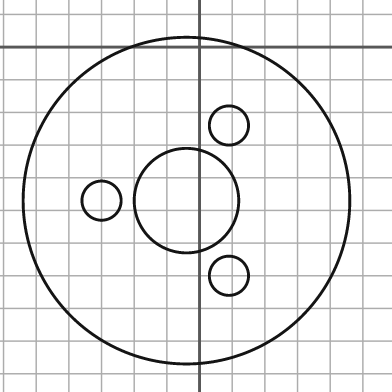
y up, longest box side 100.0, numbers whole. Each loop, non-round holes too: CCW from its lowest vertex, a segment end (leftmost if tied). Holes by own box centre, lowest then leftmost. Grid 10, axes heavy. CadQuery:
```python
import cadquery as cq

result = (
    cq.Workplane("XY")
    .moveTo(-4.0, -47.0)
    .circle(50.0)
    .moveTo(9.0, -70.0)
    .circle(6.0)
    .moveTo(-30.0, -47.0)
    .circle(6.0)
    .moveTo(-4.0, -47.0)
    .circle(16.0)
    .moveTo(9.0, -24.0)
    .circle(6.0)
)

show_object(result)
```